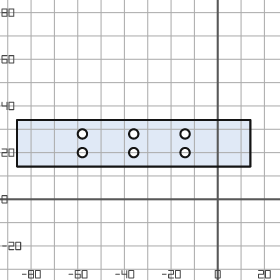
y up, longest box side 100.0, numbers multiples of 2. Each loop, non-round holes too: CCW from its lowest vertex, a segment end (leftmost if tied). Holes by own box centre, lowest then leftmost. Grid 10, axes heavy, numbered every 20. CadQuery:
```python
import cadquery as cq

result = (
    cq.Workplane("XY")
    .moveTo(-86.0, 14.0)
    .lineTo(14.0, 14.0)
    .lineTo(14.0, 34.0)
    .lineTo(-86.0, 34.0)
    .close()
    .moveTo(-58.0, 20.0)
    .circle(2.0)
    .moveTo(-36.0, 20.0)
    .circle(2.0)
    .moveTo(-14.0, 20.0)
    .circle(2.0)
    .moveTo(-58.0, 28.0)
    .circle(2.0)
    .moveTo(-36.0, 28.0)
    .circle(2.0)
    .moveTo(-14.0, 28.0)
    .circle(2.0)
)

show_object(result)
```